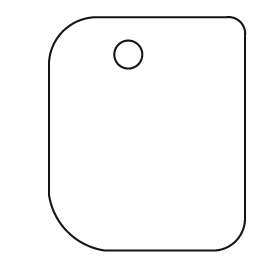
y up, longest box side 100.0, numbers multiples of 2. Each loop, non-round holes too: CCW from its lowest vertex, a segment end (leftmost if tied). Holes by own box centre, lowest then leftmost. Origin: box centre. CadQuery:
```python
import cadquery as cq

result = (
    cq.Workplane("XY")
    .moveTo(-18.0, -50.0)
    .lineTo(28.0, -50.0)
    .threePointArc((38.0, -46.0), (42.0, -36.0))
    .lineTo(42.0, 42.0)
    .threePointArc((40.0, 48.0), (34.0, 50.0))
    .lineTo(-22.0, 50.0)
    .threePointArc((-36.0, 44.0), (-42.0, 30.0))
    .lineTo(-42.0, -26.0)
    .threePointArc((-34.0, -42.0), (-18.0, -50.0))
    .close()
    .moveTo(-8.0, 34.0)
    .circle(6.0)
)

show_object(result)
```